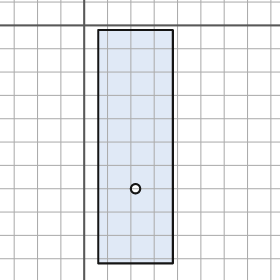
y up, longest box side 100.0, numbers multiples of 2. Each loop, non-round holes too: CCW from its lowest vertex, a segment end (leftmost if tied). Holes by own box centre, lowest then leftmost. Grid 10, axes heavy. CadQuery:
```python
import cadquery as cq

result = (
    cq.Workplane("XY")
    .moveTo(6.0, -102.0)
    .lineTo(38.0, -102.0)
    .lineTo(38.0, -2.0)
    .lineTo(6.0, -2.0)
    .close()
    .moveTo(22.0, -70.0)
    .circle(2.0)
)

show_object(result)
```